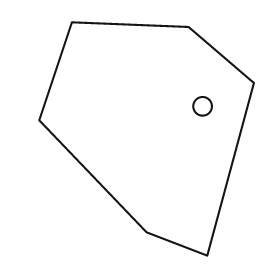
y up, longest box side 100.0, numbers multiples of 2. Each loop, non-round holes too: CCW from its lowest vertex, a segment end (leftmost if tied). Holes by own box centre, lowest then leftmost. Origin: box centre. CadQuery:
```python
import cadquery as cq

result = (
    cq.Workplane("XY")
    .moveTo(26.0, -50.0)
    .lineTo(46.0, 24.0)
    .lineTo(18.0, 48.0)
    .lineTo(-32.0, 50.0)
    .lineTo(-46.0, 8.0)
    .lineTo(0.0, -40.0)
    .close()
    .moveTo(24.0, 14.0)
    .circle(4.0)
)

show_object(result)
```